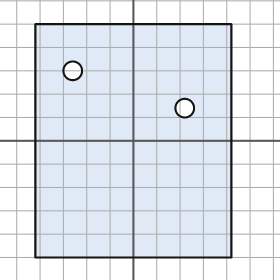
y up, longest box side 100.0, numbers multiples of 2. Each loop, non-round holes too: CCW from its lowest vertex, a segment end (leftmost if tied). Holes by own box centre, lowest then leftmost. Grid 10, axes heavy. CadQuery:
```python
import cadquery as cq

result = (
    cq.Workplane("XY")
    .moveTo(-42.0, -50.0)
    .lineTo(42.0, -50.0)
    .lineTo(42.0, 50.0)
    .lineTo(-42.0, 50.0)
    .close()
    .moveTo(22.0, 14.0)
    .circle(4.0)
    .moveTo(-26.0, 30.0)
    .circle(4.0)
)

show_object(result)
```